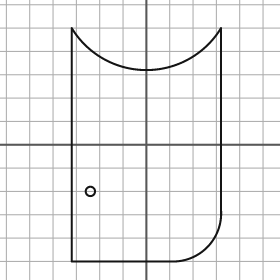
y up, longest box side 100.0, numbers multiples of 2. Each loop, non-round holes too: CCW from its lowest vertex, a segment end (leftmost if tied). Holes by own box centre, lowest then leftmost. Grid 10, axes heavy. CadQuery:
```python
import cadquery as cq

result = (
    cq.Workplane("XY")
    .moveTo(-32.0, -50.0)
    .lineTo(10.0, -50.0)
    .threePointArc((26.0, -44.0), (32.0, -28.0))
    .lineTo(32.0, 50.0)
    .threePointArc((0.0, 32.0), (-32.0, 50.0))
    .close()
    .moveTo(-24.0, -20.0)
    .circle(2.0)
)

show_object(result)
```